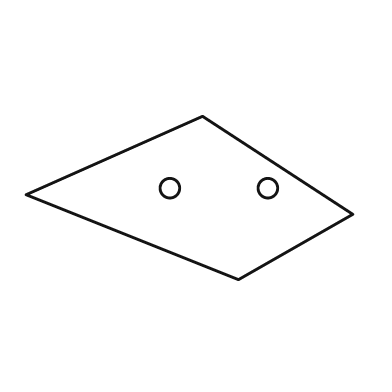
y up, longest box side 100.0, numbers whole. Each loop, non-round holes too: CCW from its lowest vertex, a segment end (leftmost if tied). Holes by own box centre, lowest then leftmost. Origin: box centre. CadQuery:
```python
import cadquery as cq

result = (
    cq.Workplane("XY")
    .moveTo(15.0, -25.0)
    .lineTo(50.0, -5.0)
    .lineTo(4.0, 25.0)
    .lineTo(-50.0, 1.0)
    .close()
    .moveTo(-6.0, 3.0)
    .circle(3.0)
    .moveTo(24.0, 3.0)
    .circle(3.0)
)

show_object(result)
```